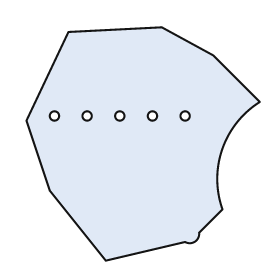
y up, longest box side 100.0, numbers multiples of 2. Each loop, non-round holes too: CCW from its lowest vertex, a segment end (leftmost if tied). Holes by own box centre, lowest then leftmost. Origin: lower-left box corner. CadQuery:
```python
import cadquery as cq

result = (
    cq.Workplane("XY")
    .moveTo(34.0, 0.0)
    .lineTo(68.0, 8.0)
    .threePointArc((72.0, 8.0), (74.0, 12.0))
    .lineTo(84.0, 22.0)
    .threePointArc((84.0, 48.0), (100.0, 68.0))
    .lineTo(80.0, 88.0)
    .lineTo(58.0, 100.0)
    .lineTo(18.0, 98.0)
    .lineTo(0.0, 60.0)
    .lineTo(10.0, 30.0)
    .close()
    .moveTo(12.0, 62.0)
    .circle(2.0)
    .moveTo(26.0, 62.0)
    .circle(2.0)
    .moveTo(40.0, 62.0)
    .circle(2.0)
    .moveTo(54.0, 62.0)
    .circle(2.0)
    .moveTo(68.0, 62.0)
    .circle(2.0)
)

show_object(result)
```